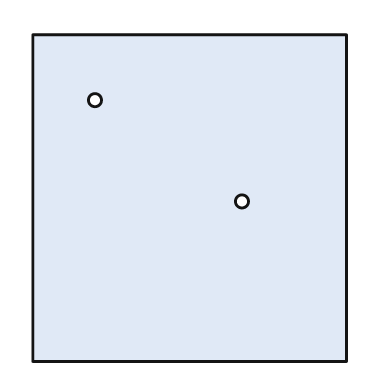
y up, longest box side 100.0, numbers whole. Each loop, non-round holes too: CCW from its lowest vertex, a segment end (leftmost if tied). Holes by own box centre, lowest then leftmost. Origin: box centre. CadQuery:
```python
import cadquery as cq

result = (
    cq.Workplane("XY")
    .moveTo(-48.0, -50.0)
    .lineTo(48.0, -50.0)
    .lineTo(48.0, 50.0)
    .lineTo(-48.0, 50.0)
    .close()
    .moveTo(16.0, -1.0)
    .circle(2.0)
    .moveTo(-29.0, 30.0)
    .circle(2.0)
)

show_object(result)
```